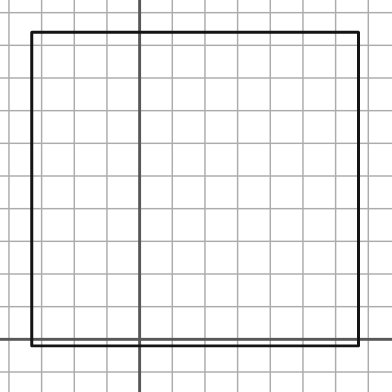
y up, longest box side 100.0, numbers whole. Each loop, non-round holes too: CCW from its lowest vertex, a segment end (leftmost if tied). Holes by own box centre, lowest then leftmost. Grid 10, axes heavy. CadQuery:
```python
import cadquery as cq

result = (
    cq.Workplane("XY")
    .moveTo(-33.0, -2.0)
    .lineTo(67.0, -2.0)
    .lineTo(67.0, 94.0)
    .lineTo(-33.0, 94.0)
    .close()
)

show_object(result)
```